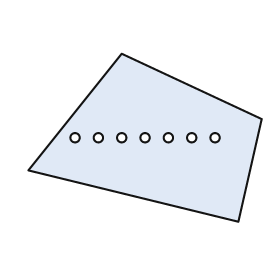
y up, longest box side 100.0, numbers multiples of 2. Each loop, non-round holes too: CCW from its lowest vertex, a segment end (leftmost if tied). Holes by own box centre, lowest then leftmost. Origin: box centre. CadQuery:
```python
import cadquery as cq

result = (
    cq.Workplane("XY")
    .moveTo(40.0, -36.0)
    .lineTo(50.0, 8.0)
    .lineTo(-10.0, 36.0)
    .lineTo(-50.0, -14.0)
    .close()
    .moveTo(-30.0, 0.0)
    .circle(2.0)
    .moveTo(-20.0, 0.0)
    .circle(2.0)
    .moveTo(-10.0, 0.0)
    .circle(2.0)
    .moveTo(0.0, 0.0)
    .circle(2.0)
    .moveTo(10.0, 0.0)
    .circle(2.0)
    .moveTo(20.0, 0.0)
    .circle(2.0)
    .moveTo(30.0, 0.0)
    .circle(2.0)
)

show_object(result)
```